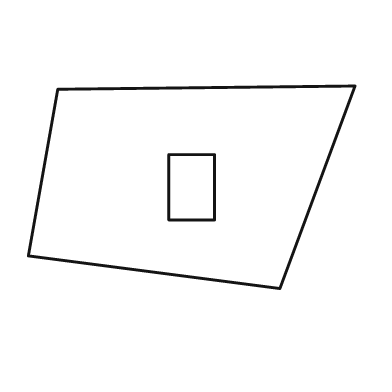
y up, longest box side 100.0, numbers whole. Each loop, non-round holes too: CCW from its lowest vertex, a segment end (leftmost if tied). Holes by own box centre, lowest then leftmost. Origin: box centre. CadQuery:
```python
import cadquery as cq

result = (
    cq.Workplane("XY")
    .moveTo(27.0, -31.0)
    .lineTo(50.0, 31.0)
    .lineTo(-41.0, 30.0)
    .lineTo(-50.0, -21.0)
    .close()
    .moveTo(-7.0, -10.0)
    .lineTo(7.0, -10.0)
    .lineTo(7.0, 10.0)
    .lineTo(-7.0, 10.0)
    .close()
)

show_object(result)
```